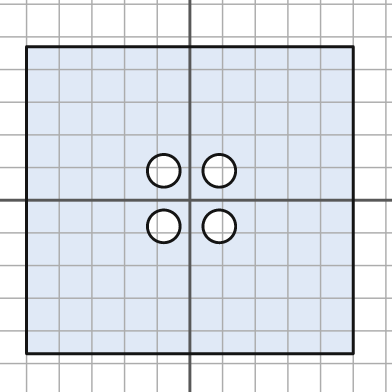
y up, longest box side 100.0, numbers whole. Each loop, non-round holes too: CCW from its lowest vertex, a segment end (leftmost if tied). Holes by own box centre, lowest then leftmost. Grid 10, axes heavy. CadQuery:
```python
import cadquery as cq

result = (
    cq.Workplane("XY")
    .moveTo(-50.0, -47.0)
    .lineTo(50.0, -47.0)
    .lineTo(50.0, 47.0)
    .lineTo(-50.0, 47.0)
    .close()
    .moveTo(-8.0, -8.0)
    .circle(5.0)
    .moveTo(9.0, -8.0)
    .circle(5.0)
    .moveTo(-8.0, 9.0)
    .circle(5.0)
    .moveTo(9.0, 9.0)
    .circle(5.0)
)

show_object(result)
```